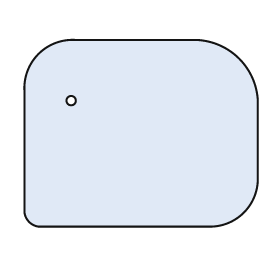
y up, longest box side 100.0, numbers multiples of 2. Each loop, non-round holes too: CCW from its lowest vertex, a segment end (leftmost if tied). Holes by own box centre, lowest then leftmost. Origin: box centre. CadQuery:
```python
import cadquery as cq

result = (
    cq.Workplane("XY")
    .moveTo(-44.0, -40.0)
    .lineTo(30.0, -40.0)
    .threePointArc((44.0, -34.0), (50.0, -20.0))
    .lineTo(50.0, 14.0)
    .threePointArc((42.0, 32.0), (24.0, 40.0))
    .lineTo(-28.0, 40.0)
    .threePointArc((-44.0, 34.0), (-50.0, 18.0))
    .lineTo(-50.0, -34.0)
    .threePointArc((-48.0, -38.0), (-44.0, -40.0))
    .close()
    .moveTo(-30.0, 14.0)
    .circle(2.0)
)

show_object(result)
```